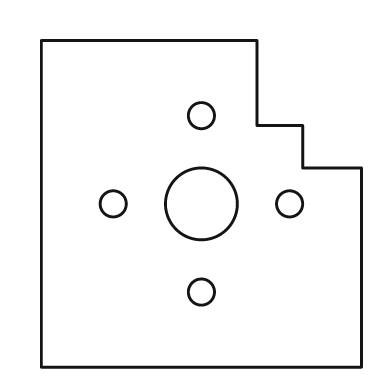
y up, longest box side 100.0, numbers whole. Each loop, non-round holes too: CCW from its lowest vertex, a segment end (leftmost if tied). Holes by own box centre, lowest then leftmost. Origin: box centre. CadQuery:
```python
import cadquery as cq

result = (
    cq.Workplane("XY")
    .moveTo(-49.0, -50.0)
    .lineTo(49.0, -50.0)
    .lineTo(49.0, 11.0)
    .lineTo(31.0, 11.0)
    .lineTo(31.0, 24.0)
    .lineTo(17.0, 24.0)
    .lineTo(17.0, 50.0)
    .lineTo(-49.0, 50.0)
    .close()
    .moveTo(0.0, -27.0)
    .circle(4.0)
    .moveTo(-27.0, 0.0)
    .circle(4.0)
    .moveTo(0.0, 0.0)
    .circle(11.0)
    .moveTo(27.0, 0.0)
    .circle(4.0)
    .moveTo(0.0, 27.0)
    .circle(4.0)
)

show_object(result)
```